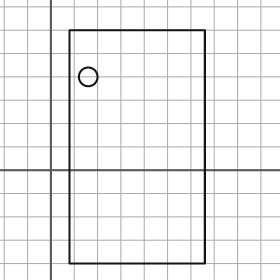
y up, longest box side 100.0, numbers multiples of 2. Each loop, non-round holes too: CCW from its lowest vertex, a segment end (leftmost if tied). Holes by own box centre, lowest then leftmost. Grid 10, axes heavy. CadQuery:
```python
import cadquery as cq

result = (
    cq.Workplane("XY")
    .moveTo(8.0, -40.0)
    .lineTo(66.0, -40.0)
    .lineTo(66.0, 60.0)
    .lineTo(8.0, 60.0)
    .close()
    .moveTo(16.0, 40.0)
    .circle(4.0)
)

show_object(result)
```